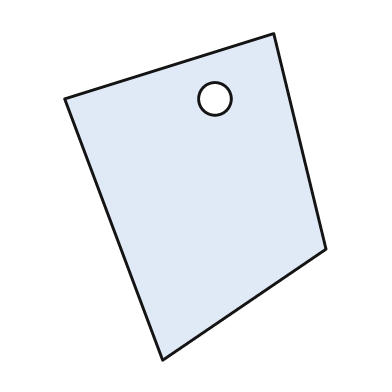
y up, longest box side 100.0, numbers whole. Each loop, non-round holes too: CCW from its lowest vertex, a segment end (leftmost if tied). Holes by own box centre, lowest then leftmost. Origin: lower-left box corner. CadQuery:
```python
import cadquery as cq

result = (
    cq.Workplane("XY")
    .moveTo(30.0, 0.0)
    .lineTo(80.0, 34.0)
    .lineTo(64.0, 100.0)
    .lineTo(0.0, 80.0)
    .close()
    .moveTo(46.0, 80.0)
    .circle(5.0)
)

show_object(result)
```